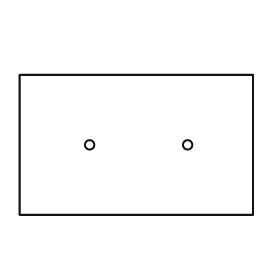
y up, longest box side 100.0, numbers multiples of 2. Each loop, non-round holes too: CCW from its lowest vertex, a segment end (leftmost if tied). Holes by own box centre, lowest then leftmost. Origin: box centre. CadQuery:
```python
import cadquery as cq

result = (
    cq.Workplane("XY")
    .moveTo(-50.0, -30.0)
    .lineTo(50.0, -30.0)
    .lineTo(50.0, 30.0)
    .lineTo(-50.0, 30.0)
    .close()
    .moveTo(-20.0, 0.0)
    .circle(2.0)
    .moveTo(22.0, 0.0)
    .circle(2.0)
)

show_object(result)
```